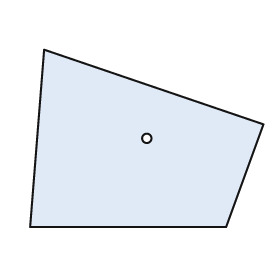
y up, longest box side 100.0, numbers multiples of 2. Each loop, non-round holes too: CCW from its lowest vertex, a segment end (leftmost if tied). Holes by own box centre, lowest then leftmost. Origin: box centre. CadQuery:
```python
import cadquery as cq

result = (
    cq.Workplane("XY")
    .moveTo(-50.0, -38.0)
    .lineTo(34.0, -38.0)
    .lineTo(50.0, 6.0)
    .lineTo(-44.0, 38.0)
    .close()
    .moveTo(0.0, 0.0)
    .circle(2.0)
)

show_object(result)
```